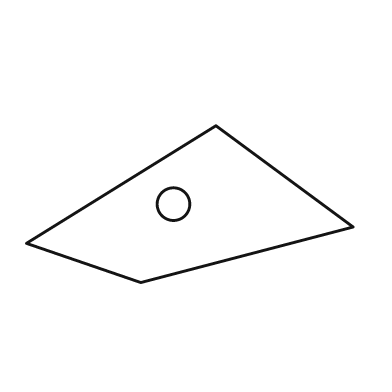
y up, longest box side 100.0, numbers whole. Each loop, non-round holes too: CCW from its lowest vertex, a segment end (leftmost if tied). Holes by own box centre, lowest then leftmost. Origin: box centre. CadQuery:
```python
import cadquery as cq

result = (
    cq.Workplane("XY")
    .moveTo(-15.0, -24.0)
    .lineTo(50.0, -7.0)
    .lineTo(8.0, 24.0)
    .lineTo(-50.0, -12.0)
    .close()
    .moveTo(-5.0, 0.0)
    .circle(5.0)
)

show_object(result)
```